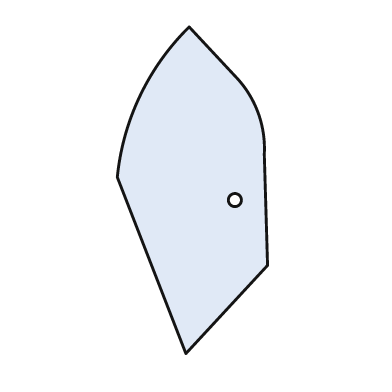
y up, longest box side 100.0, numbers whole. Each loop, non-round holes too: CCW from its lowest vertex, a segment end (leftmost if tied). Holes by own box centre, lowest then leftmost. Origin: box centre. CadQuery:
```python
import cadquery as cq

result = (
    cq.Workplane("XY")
    .moveTo(-2.0, -50.0)
    .lineTo(23.0, -23.0)
    .lineTo(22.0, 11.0)
    .threePointArc((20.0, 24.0), (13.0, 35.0))
    .lineTo(-1.0, 50.0)
    .threePointArc((-16.0, 29.0), (-23.0, 4.0))
    .close()
    .moveTo(13.0, -3.0)
    .circle(2.0)
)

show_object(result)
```